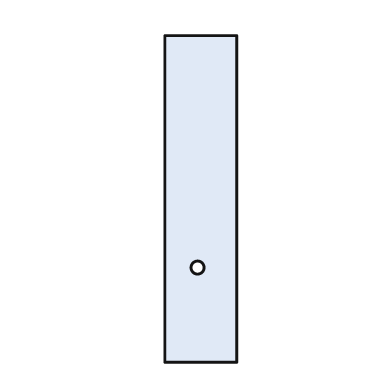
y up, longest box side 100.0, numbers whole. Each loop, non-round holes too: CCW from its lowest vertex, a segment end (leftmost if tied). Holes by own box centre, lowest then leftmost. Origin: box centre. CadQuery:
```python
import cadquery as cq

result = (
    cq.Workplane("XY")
    .moveTo(-11.0, -50.0)
    .lineTo(11.0, -50.0)
    .lineTo(11.0, 50.0)
    .lineTo(-11.0, 50.0)
    .close()
    .moveTo(-1.0, -21.0)
    .circle(2.0)
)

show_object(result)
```